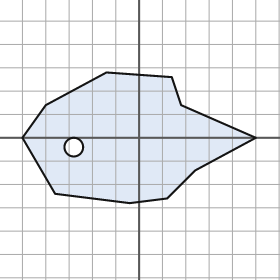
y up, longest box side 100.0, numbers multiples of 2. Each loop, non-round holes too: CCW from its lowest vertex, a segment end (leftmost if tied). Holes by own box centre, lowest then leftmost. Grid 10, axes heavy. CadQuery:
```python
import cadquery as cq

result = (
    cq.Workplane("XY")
    .moveTo(-4.0, -28.0)
    .lineTo(12.0, -26.0)
    .lineTo(24.0, -14.0)
    .lineTo(50.0, 0.0)
    .lineTo(18.0, 14.0)
    .lineTo(14.0, 26.0)
    .lineTo(-14.0, 28.0)
    .lineTo(-40.0, 14.0)
    .lineTo(-50.0, 0.0)
    .lineTo(-36.0, -24.0)
    .close()
    .moveTo(-28.0, -4.0)
    .circle(4.0)
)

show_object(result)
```